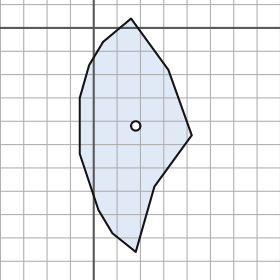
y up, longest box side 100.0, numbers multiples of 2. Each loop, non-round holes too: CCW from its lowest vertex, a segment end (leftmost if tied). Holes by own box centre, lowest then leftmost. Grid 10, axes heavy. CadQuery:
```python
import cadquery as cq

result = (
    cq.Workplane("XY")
    .moveTo(18.0, -96.0)
    .lineTo(26.0, -68.0)
    .lineTo(42.0, -46.0)
    .lineTo(32.0, -18.0)
    .lineTo(16.0, 4.0)
    .lineTo(4.0, -6.0)
    .lineTo(-2.0, -16.0)
    .lineTo(-6.0, -30.0)
    .lineTo(-6.0, -54.0)
    .lineTo(2.0, -78.0)
    .lineTo(8.0, -88.0)
    .close()
    .moveTo(18.0, -42.0)
    .circle(2.0)
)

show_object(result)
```